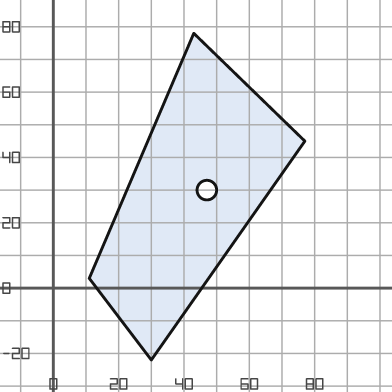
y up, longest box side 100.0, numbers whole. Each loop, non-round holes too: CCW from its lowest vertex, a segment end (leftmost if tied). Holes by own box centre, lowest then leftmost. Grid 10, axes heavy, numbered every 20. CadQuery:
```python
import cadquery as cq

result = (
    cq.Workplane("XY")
    .moveTo(30.0, -22.0)
    .lineTo(77.0, 45.0)
    .lineTo(43.0, 78.0)
    .lineTo(11.0, 3.0)
    .close()
    .moveTo(47.0, 30.0)
    .circle(3.0)
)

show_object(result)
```